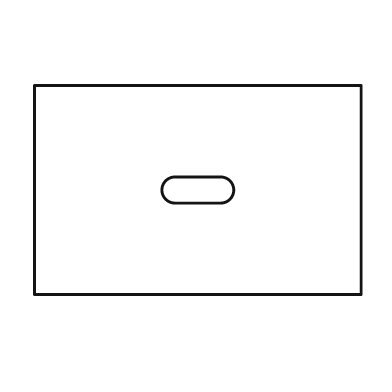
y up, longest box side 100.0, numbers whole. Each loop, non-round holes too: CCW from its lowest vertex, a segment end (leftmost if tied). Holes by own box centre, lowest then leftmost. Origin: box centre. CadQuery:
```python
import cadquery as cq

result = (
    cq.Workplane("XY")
    .moveTo(-50.0, -32.0)
    .lineTo(50.0, -32.0)
    .lineTo(50.0, 32.0)
    .lineTo(-50.0, 32.0)
    .close()
    .moveTo(-7.0, -4.0)
    .lineTo(7.0, -4.0)
    .threePointArc((11.0, 0.0), (7.0, 4.0))
    .lineTo(-7.0, 4.0)
    .threePointArc((-11.0, 0.0), (-7.0, -4.0))
    .close()
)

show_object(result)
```